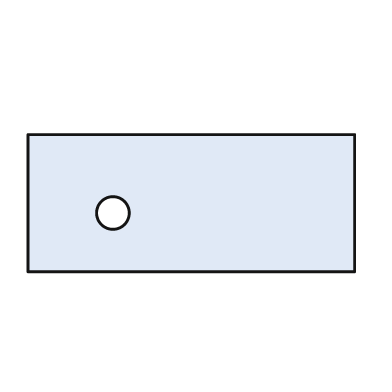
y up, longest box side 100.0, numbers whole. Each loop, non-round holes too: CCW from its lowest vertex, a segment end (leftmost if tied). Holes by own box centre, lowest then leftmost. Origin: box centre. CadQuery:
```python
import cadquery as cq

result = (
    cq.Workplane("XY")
    .moveTo(-50.0, -21.0)
    .lineTo(50.0, -21.0)
    .lineTo(50.0, 21.0)
    .lineTo(-50.0, 21.0)
    .close()
    .moveTo(-24.0, -3.0)
    .circle(5.0)
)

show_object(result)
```